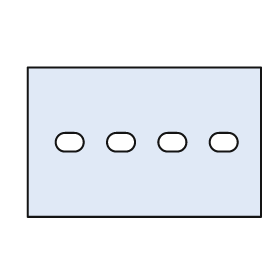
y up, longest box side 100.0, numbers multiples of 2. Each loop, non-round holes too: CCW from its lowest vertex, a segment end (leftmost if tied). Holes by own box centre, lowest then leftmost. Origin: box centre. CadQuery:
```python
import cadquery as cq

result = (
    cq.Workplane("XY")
    .moveTo(-50.0, -32.0)
    .lineTo(50.0, -32.0)
    .lineTo(50.0, 32.0)
    .lineTo(-50.0, 32.0)
    .close()
    .moveTo(-34.0, -4.0)
    .lineTo(-30.0, -4.0)
    .threePointArc((-26.0, 0.0), (-30.0, 4.0))
    .lineTo(-34.0, 4.0)
    .threePointArc((-38.0, 0.0), (-34.0, -4.0))
    .close()
    .moveTo(-12.0, -4.0)
    .lineTo(-8.0, -4.0)
    .threePointArc((-4.0, 0.0), (-8.0, 4.0))
    .lineTo(-12.0, 4.0)
    .threePointArc((-16.0, 0.0), (-12.0, -4.0))
    .close()
    .moveTo(10.0, -4.0)
    .lineTo(14.0, -4.0)
    .threePointArc((18.0, 0.0), (14.0, 4.0))
    .lineTo(10.0, 4.0)
    .threePointArc((6.0, 0.0), (10.0, -4.0))
    .close()
    .moveTo(32.0, -4.0)
    .lineTo(36.0, -4.0)
    .threePointArc((40.0, 0.0), (36.0, 4.0))
    .lineTo(32.0, 4.0)
    .threePointArc((28.0, 0.0), (32.0, -4.0))
    .close()
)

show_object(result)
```